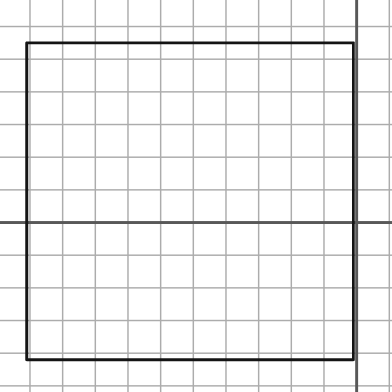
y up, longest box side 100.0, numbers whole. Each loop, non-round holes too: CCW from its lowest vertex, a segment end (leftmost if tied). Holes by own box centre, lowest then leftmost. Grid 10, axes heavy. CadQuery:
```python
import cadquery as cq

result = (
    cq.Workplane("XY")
    .moveTo(-101.0, -42.0)
    .lineTo(-1.0, -42.0)
    .lineTo(-1.0, 55.0)
    .lineTo(-101.0, 55.0)
    .close()
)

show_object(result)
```